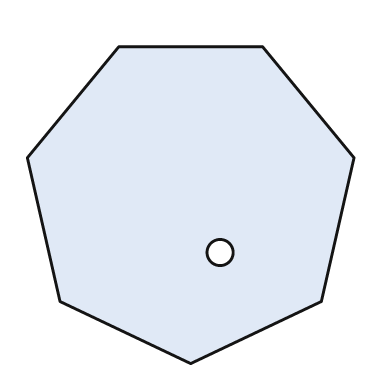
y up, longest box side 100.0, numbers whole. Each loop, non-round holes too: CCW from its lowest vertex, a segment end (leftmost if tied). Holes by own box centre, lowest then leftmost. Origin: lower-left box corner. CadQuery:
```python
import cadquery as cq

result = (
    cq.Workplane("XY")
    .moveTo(50.0, 0.0)
    .lineTo(90.0, 19.0)
    .lineTo(100.0, 63.0)
    .lineTo(72.0, 97.0)
    .lineTo(28.0, 97.0)
    .lineTo(0.0, 63.0)
    .lineTo(10.0, 19.0)
    .close()
    .moveTo(59.0, 34.0)
    .circle(4.0)
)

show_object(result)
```